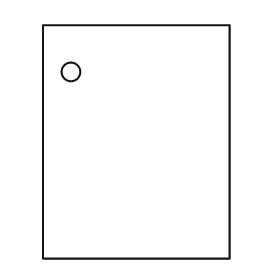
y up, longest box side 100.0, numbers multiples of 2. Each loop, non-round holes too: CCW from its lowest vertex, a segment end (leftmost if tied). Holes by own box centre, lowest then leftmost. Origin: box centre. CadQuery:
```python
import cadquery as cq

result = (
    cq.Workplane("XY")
    .moveTo(-40.0, -50.0)
    .lineTo(40.0, -50.0)
    .lineTo(40.0, 50.0)
    .lineTo(-40.0, 50.0)
    .close()
    .moveTo(-28.0, 30.0)
    .circle(4.0)
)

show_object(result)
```